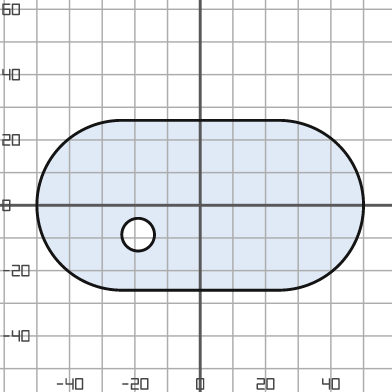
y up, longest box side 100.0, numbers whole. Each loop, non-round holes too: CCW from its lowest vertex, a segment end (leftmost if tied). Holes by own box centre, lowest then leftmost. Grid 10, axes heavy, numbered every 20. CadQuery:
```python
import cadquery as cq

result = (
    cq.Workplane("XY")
    .moveTo(-24.0, -26.0)
    .lineTo(24.0, -26.0)
    .threePointArc((50.0, 0.0), (24.0, 26.0))
    .lineTo(-24.0, 26.0)
    .threePointArc((-50.0, 0.0), (-24.0, -26.0))
    .close()
    .moveTo(-19.0, -9.0)
    .circle(5.0)
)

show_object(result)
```